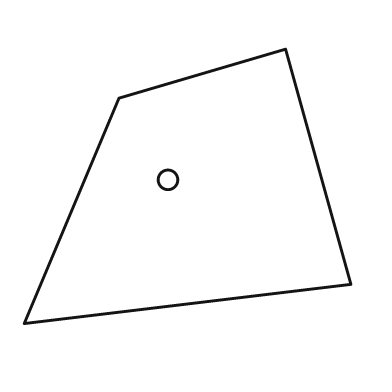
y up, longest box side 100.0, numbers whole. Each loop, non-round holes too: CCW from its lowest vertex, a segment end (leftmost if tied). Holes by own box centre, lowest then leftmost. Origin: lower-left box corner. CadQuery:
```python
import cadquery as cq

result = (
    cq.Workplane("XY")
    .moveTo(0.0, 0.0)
    .lineTo(100.0, 12.0)
    .lineTo(80.0, 84.0)
    .lineTo(29.0, 69.0)
    .close()
    .moveTo(44.0, 44.0)
    .circle(3.0)
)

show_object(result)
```